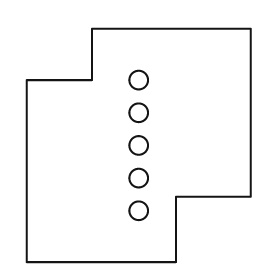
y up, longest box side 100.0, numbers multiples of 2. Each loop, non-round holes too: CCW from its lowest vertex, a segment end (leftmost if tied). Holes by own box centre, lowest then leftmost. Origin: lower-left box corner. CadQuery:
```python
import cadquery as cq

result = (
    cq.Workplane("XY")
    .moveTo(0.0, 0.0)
    .lineTo(64.0, 0.0)
    .lineTo(64.0, 28.0)
    .lineTo(96.0, 28.0)
    .lineTo(96.0, 100.0)
    .lineTo(28.0, 100.0)
    .lineTo(28.0, 78.0)
    .lineTo(0.0, 78.0)
    .close()
    .moveTo(48.0, 22.0)
    .circle(4.0)
    .moveTo(48.0, 36.0)
    .circle(4.0)
    .moveTo(48.0, 50.0)
    .circle(4.0)
    .moveTo(48.0, 64.0)
    .circle(4.0)
    .moveTo(48.0, 78.0)
    .circle(4.0)
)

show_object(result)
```